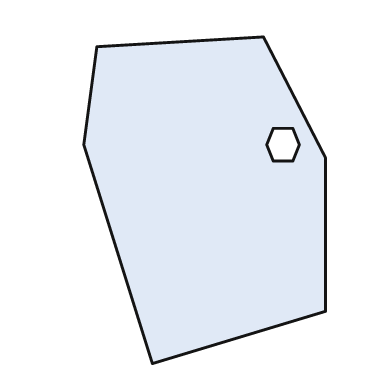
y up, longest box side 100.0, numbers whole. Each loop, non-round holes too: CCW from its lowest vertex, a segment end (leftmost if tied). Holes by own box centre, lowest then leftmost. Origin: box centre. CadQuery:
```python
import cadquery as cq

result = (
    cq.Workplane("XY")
    .moveTo(-16.0, -50.0)
    .lineTo(37.0, -34.0)
    .lineTo(37.0, 13.0)
    .lineTo(18.0, 50.0)
    .lineTo(-33.0, 47.0)
    .lineTo(-37.0, 17.0)
    .close()
    .moveTo(21.0, 12.0)
    .lineTo(27.0, 12.0)
    .lineTo(29.0, 17.0)
    .lineTo(27.0, 22.0)
    .lineTo(21.0, 22.0)
    .lineTo(19.0, 17.0)
    .close()
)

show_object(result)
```